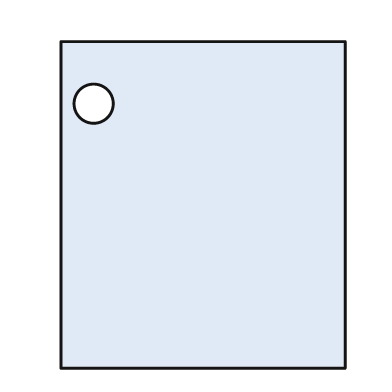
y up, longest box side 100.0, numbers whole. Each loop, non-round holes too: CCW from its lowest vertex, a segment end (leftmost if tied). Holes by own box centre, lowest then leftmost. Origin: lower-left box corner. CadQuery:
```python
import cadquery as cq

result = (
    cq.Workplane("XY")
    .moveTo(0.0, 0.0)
    .lineTo(87.0, 0.0)
    .lineTo(87.0, 100.0)
    .lineTo(0.0, 100.0)
    .close()
    .moveTo(10.0, 81.0)
    .circle(6.0)
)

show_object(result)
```